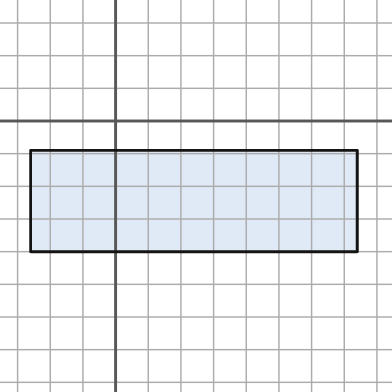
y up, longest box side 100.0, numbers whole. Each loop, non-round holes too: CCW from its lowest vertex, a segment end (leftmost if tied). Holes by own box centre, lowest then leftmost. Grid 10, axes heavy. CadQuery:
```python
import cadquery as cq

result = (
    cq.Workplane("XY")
    .moveTo(-26.0, -40.0)
    .lineTo(74.0, -40.0)
    .lineTo(74.0, -9.0)
    .lineTo(-26.0, -9.0)
    .close()
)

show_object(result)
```